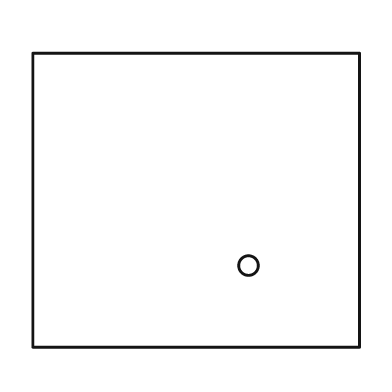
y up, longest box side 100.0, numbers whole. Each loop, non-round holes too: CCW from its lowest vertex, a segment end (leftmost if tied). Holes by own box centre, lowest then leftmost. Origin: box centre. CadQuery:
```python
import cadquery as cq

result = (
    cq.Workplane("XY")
    .moveTo(-50.0, -45.0)
    .lineTo(50.0, -45.0)
    .lineTo(50.0, 45.0)
    .lineTo(-50.0, 45.0)
    .close()
    .moveTo(16.0, -20.0)
    .circle(3.0)
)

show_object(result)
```